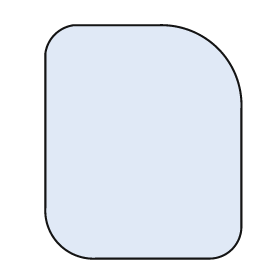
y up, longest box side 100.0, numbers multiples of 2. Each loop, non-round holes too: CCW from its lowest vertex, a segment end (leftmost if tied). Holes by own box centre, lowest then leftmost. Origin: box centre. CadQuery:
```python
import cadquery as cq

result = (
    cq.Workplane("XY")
    .moveTo(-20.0, -50.0)
    .lineTo(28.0, -50.0)
    .threePointArc((38.0, -46.0), (42.0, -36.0))
    .lineTo(42.0, 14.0)
    .threePointArc((32.0, 40.0), (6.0, 50.0))
    .lineTo(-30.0, 50.0)
    .threePointArc((-38.0, 46.0), (-42.0, 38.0))
    .lineTo(-42.0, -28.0)
    .threePointArc((-36.0, -44.0), (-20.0, -50.0))
    .close()
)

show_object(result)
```